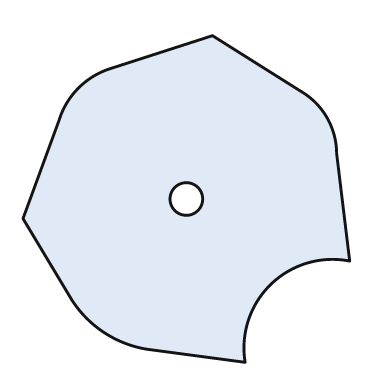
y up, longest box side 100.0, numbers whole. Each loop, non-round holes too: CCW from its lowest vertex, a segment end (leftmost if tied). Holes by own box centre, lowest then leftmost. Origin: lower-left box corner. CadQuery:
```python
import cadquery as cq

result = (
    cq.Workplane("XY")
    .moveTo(68.0, 0.0)
    .threePointArc((76.0, 24.0), (100.0, 31.0))
    .lineTo(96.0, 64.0)
    .threePointArc((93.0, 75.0), (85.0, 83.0))
    .lineTo(58.0, 100.0)
    .lineTo(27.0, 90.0)
    .threePointArc((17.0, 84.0), (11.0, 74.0))
    .lineTo(0.0, 44.0)
    .lineTo(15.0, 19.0)
    .threePointArc((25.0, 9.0), (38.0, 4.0))
    .close()
    .moveTo(50.0, 50.0)
    .circle(5.0)
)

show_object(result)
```